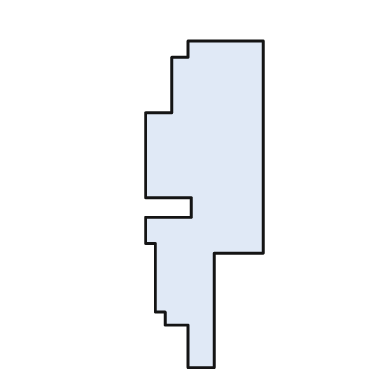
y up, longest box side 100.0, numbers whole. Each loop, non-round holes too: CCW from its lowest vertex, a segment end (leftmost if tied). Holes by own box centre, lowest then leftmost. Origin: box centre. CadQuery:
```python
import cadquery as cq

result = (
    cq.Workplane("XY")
    .moveTo(-5.0, -50.0)
    .lineTo(3.0, -50.0)
    .lineTo(3.0, -15.0)
    .lineTo(18.0, -15.0)
    .lineTo(18.0, 50.0)
    .lineTo(-5.0, 50.0)
    .lineTo(-5.0, 45.0)
    .lineTo(-10.0, 45.0)
    .lineTo(-10.0, 28.0)
    .lineTo(-18.0, 28.0)
    .lineTo(-18.0, 2.0)
    .lineTo(-4.0, 2.0)
    .lineTo(-4.0, -4.0)
    .lineTo(-18.0, -4.0)
    .lineTo(-18.0, -12.0)
    .lineTo(-15.0, -12.0)
    .lineTo(-15.0, -33.0)
    .lineTo(-12.0, -33.0)
    .lineTo(-12.0, -37.0)
    .lineTo(-5.0, -37.0)
    .close()
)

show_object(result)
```